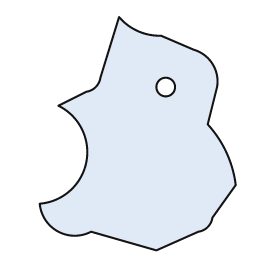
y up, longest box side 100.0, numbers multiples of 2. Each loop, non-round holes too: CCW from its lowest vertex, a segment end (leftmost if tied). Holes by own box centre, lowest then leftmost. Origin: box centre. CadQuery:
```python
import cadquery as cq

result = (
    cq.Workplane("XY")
    .moveTo(8.0, -50.0)
    .lineTo(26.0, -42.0)
    .threePointArc((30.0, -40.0), (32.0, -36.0))
    .lineTo(42.0, -22.0)
    .threePointArc((38.0, -8.0), (30.0, 4.0))
    .lineTo(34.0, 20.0)
    .threePointArc((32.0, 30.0), (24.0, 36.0))
    .lineTo(10.0, 42.0)
    .threePointArc((0.0, 44.0), (-8.0, 50.0))
    .lineTo(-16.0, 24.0)
    .threePointArc((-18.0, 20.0), (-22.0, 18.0))
    .lineTo(-34.0, 12.0)
    .threePointArc((-22.0, -12.0), (-42.0, -30.0))
    .threePointArc((-34.0, -42.0), (-20.0, -42.0))
    .close()
    .moveTo(12.0, 20.0)
    .circle(4.0)
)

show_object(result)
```